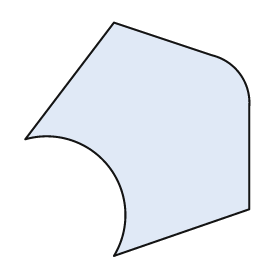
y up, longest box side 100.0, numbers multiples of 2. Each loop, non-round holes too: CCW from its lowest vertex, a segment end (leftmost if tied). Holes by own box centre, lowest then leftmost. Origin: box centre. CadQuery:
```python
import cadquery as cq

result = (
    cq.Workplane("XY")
    .moveTo(-10.0, -50.0)
    .lineTo(48.0, -30.0)
    .lineTo(48.0, 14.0)
    .threePointArc((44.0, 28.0), (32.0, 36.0))
    .lineTo(-10.0, 50.0)
    .lineTo(-48.0, 0.0)
    .threePointArc((-12.0, -12.0), (-10.0, -50.0))
    .close()
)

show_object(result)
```